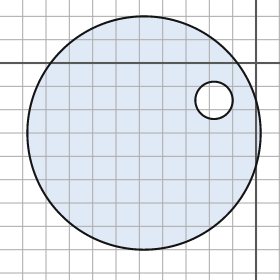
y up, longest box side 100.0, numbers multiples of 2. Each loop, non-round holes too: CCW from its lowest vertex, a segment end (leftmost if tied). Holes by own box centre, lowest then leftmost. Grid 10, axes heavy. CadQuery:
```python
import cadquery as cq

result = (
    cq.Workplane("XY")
    .moveTo(-48.0, -30.0)
    .circle(50.0)
    .moveTo(-18.0, -16.0)
    .circle(8.0)
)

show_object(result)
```